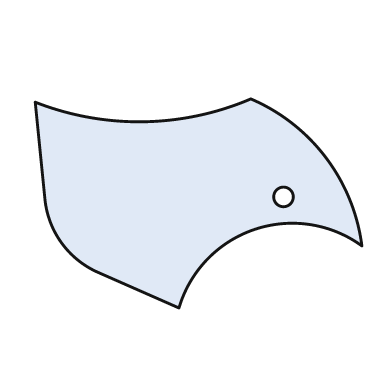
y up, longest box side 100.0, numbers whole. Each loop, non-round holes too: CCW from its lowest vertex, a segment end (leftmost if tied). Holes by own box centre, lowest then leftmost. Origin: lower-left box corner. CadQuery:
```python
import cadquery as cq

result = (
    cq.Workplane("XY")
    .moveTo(44.0, 0.0)
    .threePointArc((67.0, 24.0), (100.0, 19.0))
    .threePointArc((89.0, 46.0), (66.0, 64.0))
    .threePointArc((33.0, 57.0), (0.0, 63.0))
    .lineTo(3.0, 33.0)
    .threePointArc((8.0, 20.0), (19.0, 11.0))
    .close()
    .moveTo(76.0, 34.0)
    .circle(3.0)
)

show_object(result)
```